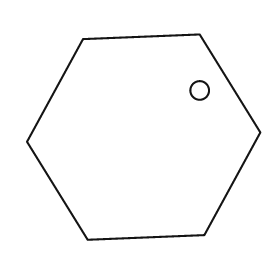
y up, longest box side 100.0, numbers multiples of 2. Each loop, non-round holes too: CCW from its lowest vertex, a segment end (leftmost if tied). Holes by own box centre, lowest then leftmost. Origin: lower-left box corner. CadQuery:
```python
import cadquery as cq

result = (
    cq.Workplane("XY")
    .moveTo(26.0, 0.0)
    .lineTo(76.0, 2.0)
    .lineTo(100.0, 46.0)
    .lineTo(74.0, 88.0)
    .lineTo(24.0, 86.0)
    .lineTo(0.0, 42.0)
    .close()
    .moveTo(74.0, 64.0)
    .circle(4.0)
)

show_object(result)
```